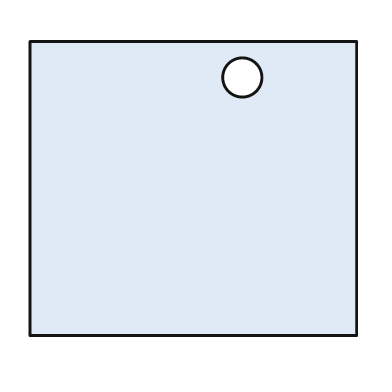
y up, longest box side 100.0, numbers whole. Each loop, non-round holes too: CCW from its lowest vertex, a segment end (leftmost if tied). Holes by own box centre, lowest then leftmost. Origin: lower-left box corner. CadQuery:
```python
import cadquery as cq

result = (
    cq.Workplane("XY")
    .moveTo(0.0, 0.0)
    .lineTo(100.0, 0.0)
    .lineTo(100.0, 90.0)
    .lineTo(0.0, 90.0)
    .close()
    .moveTo(65.0, 79.0)
    .circle(6.0)
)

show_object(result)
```